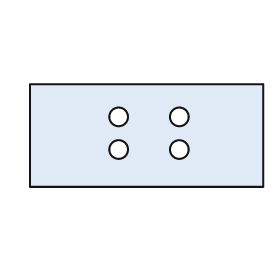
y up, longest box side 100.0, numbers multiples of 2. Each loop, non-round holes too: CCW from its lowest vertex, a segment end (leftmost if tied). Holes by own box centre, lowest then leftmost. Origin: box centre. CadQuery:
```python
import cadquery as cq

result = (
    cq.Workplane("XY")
    .moveTo(-50.0, -22.0)
    .lineTo(50.0, -22.0)
    .lineTo(50.0, 22.0)
    .lineTo(-50.0, 22.0)
    .close()
    .moveTo(-12.0, -6.0)
    .circle(4.0)
    .moveTo(14.0, -6.0)
    .circle(4.0)
    .moveTo(-12.0, 8.0)
    .circle(4.0)
    .moveTo(14.0, 8.0)
    .circle(4.0)
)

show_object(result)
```